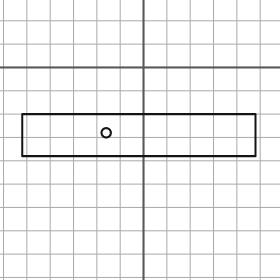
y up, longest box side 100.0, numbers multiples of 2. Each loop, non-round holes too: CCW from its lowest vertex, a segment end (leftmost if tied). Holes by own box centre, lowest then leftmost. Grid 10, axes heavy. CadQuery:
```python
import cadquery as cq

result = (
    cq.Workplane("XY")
    .moveTo(-52.0, -38.0)
    .lineTo(48.0, -38.0)
    .lineTo(48.0, -20.0)
    .lineTo(-52.0, -20.0)
    .close()
    .moveTo(-16.0, -28.0)
    .circle(2.0)
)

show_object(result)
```